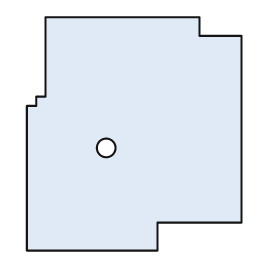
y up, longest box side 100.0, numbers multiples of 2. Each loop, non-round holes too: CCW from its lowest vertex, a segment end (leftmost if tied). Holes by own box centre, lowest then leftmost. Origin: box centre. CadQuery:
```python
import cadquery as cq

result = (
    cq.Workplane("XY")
    .moveTo(-46.0, -50.0)
    .lineTo(10.0, -50.0)
    .lineTo(10.0, -38.0)
    .lineTo(46.0, -38.0)
    .lineTo(46.0, 42.0)
    .lineTo(28.0, 42.0)
    .lineTo(28.0, 50.0)
    .lineTo(-38.0, 50.0)
    .lineTo(-38.0, 16.0)
    .lineTo(-42.0, 16.0)
    .lineTo(-42.0, 12.0)
    .lineTo(-46.0, 12.0)
    .close()
    .moveTo(-12.0, -6.0)
    .circle(4.0)
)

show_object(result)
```